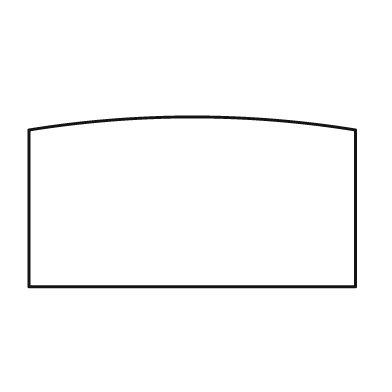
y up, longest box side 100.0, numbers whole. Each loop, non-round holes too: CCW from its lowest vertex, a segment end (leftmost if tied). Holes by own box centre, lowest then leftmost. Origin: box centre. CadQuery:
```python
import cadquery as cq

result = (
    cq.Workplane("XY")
    .moveTo(-50.0, -26.0)
    .lineTo(50.0, -26.0)
    .lineTo(50.0, 22.0)
    .threePointArc((0.0, 26.0), (-50.0, 22.0))
    .close()
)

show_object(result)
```